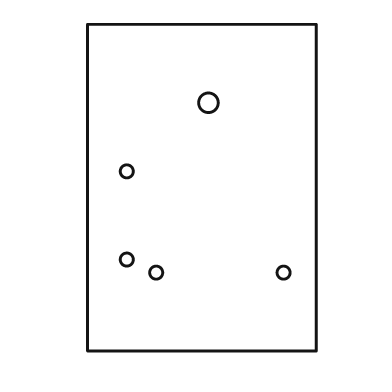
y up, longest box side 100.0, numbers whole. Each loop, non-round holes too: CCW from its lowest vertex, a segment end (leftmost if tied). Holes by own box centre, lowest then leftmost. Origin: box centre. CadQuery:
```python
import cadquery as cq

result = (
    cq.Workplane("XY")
    .moveTo(-35.0, -50.0)
    .lineTo(35.0, -50.0)
    .lineTo(35.0, 50.0)
    .lineTo(-35.0, 50.0)
    .close()
    .moveTo(-14.0, -26.0)
    .circle(2.0)
    .moveTo(25.0, -26.0)
    .circle(2.0)
    .moveTo(-23.0, -22.0)
    .circle(2.0)
    .moveTo(-23.0, 5.0)
    .circle(2.0)
    .moveTo(2.0, 26.0)
    .circle(3.0)
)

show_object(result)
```